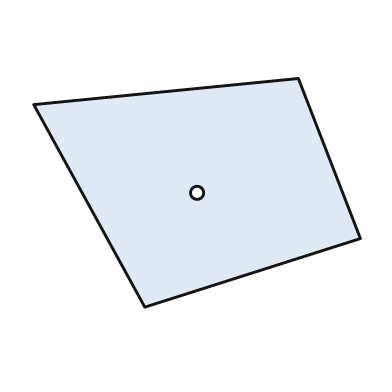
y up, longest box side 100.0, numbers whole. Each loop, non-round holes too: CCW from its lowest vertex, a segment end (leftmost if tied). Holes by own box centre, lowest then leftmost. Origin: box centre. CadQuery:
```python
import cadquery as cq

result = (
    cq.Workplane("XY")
    .moveTo(-16.0, -35.0)
    .lineTo(50.0, -14.0)
    .lineTo(31.0, 35.0)
    .lineTo(-50.0, 27.0)
    .close()
    .moveTo(0.0, 0.0)
    .circle(2.0)
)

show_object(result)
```